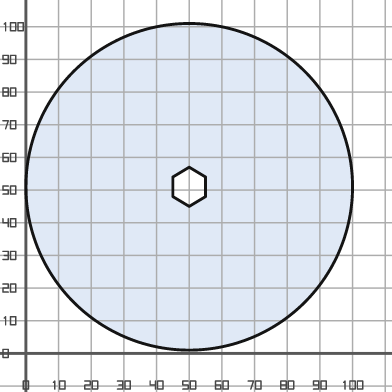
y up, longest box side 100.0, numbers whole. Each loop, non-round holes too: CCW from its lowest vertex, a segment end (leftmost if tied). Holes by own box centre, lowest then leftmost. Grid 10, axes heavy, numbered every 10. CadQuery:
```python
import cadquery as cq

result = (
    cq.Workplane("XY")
    .moveTo(50.0, 51.0)
    .circle(50.0)
    .moveTo(50.0, 45.0)
    .lineTo(55.0, 48.0)
    .lineTo(55.0, 54.0)
    .lineTo(50.0, 57.0)
    .lineTo(45.0, 54.0)
    .lineTo(45.0, 48.0)
    .close()
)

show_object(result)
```